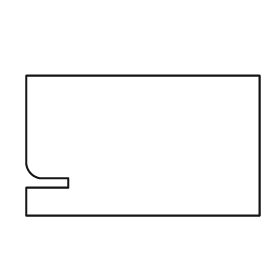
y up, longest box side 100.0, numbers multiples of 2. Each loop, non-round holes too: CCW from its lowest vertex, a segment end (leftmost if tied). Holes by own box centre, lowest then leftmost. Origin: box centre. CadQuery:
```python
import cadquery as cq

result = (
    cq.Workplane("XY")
    .moveTo(-50.0, -30.0)
    .lineTo(50.0, -30.0)
    .lineTo(50.0, 30.0)
    .lineTo(-50.0, 30.0)
    .lineTo(-50.0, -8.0)
    .threePointArc((-48.0, -12.0), (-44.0, -14.0))
    .lineTo(-32.0, -14.0)
    .lineTo(-32.0, -18.0)
    .lineTo(-50.0, -18.0)
    .close()
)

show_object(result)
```